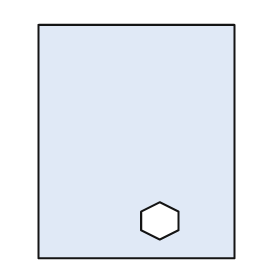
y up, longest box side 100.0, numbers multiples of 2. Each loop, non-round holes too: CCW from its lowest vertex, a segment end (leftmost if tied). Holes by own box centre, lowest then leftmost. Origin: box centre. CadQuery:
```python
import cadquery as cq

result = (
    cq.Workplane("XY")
    .moveTo(-42.0, -50.0)
    .lineTo(42.0, -50.0)
    .lineTo(42.0, 50.0)
    .lineTo(-42.0, 50.0)
    .close()
    .moveTo(10.0, -42.0)
    .lineTo(18.0, -38.0)
    .lineTo(18.0, -30.0)
    .lineTo(10.0, -26.0)
    .lineTo(2.0, -30.0)
    .lineTo(2.0, -38.0)
    .close()
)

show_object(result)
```